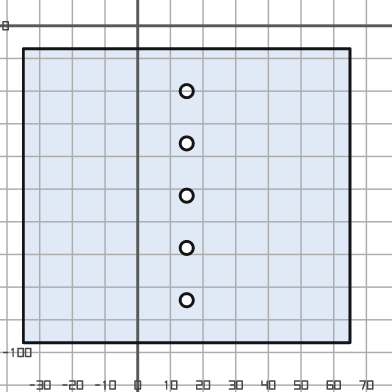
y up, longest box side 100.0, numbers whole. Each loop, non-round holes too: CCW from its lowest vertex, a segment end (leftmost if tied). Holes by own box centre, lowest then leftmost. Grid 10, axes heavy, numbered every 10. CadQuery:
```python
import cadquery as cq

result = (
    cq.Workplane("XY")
    .moveTo(-35.0, -97.0)
    .lineTo(65.0, -97.0)
    .lineTo(65.0, -7.0)
    .lineTo(-35.0, -7.0)
    .close()
    .moveTo(15.0, -84.0)
    .circle(2.0)
    .moveTo(15.0, -68.0)
    .circle(2.0)
    .moveTo(15.0, -52.0)
    .circle(2.0)
    .moveTo(15.0, -36.0)
    .circle(2.0)
    .moveTo(15.0, -20.0)
    .circle(2.0)
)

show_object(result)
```